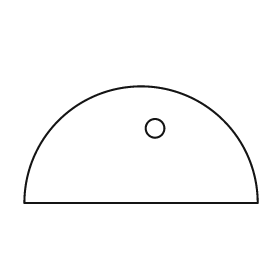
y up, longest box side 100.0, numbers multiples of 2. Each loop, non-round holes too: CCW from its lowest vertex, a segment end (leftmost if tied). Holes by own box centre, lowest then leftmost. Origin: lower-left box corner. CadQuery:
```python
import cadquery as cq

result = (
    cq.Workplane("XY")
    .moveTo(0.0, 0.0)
    .lineTo(100.0, 0.0)
    .threePointArc((50.0, 50.0), (0.0, 0.0))
    .close()
    .moveTo(56.0, 32.0)
    .circle(4.0)
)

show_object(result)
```